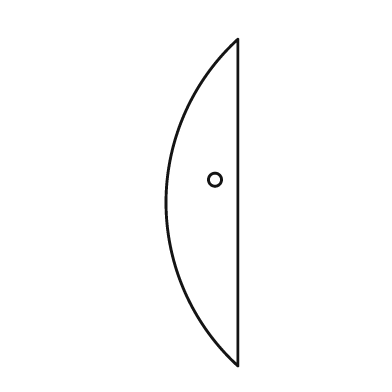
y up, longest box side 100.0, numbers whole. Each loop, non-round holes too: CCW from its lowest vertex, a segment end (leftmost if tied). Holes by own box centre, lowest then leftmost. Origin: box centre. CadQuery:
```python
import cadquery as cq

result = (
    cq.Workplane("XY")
    .moveTo(11.0, -50.0)
    .lineTo(11.0, 50.0)
    .threePointArc((-11.0, 0.0), (11.0, -50.0))
    .close()
    .moveTo(4.0, 7.0)
    .circle(2.0)
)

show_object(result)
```